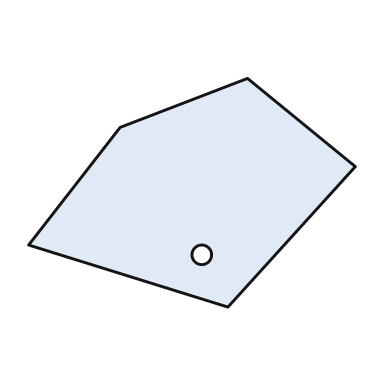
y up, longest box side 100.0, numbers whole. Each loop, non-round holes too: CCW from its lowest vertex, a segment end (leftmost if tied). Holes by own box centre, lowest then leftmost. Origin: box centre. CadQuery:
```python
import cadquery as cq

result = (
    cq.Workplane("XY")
    .moveTo(11.0, -35.0)
    .lineTo(50.0, 8.0)
    .lineTo(17.0, 35.0)
    .lineTo(-22.0, 20.0)
    .lineTo(-50.0, -16.0)
    .close()
    .moveTo(3.0, -19.0)
    .circle(3.0)
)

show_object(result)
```